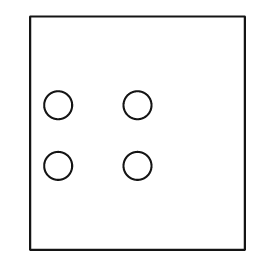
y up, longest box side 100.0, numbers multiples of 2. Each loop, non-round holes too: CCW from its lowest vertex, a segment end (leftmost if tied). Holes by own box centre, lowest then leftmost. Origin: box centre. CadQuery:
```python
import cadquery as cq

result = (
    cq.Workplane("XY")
    .moveTo(-46.0, -50.0)
    .lineTo(46.0, -50.0)
    .lineTo(46.0, 50.0)
    .lineTo(-46.0, 50.0)
    .close()
    .moveTo(-34.0, -14.0)
    .circle(6.0)
    .moveTo(0.0, -14.0)
    .circle(6.0)
    .moveTo(-34.0, 12.0)
    .circle(6.0)
    .moveTo(0.0, 12.0)
    .circle(6.0)
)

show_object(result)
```